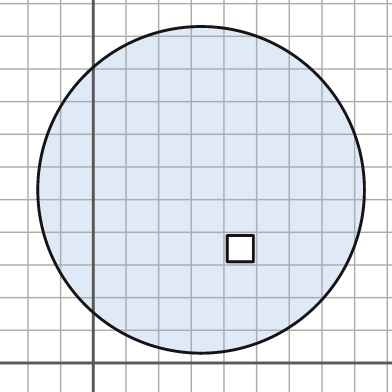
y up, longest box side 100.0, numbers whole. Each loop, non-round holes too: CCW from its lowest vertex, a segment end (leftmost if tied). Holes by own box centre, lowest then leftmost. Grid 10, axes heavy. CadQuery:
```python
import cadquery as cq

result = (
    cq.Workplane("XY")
    .moveTo(33.0, 53.0)
    .circle(50.0)
    .moveTo(41.0, 31.0)
    .lineTo(49.0, 31.0)
    .lineTo(49.0, 39.0)
    .lineTo(41.0, 39.0)
    .close()
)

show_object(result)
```